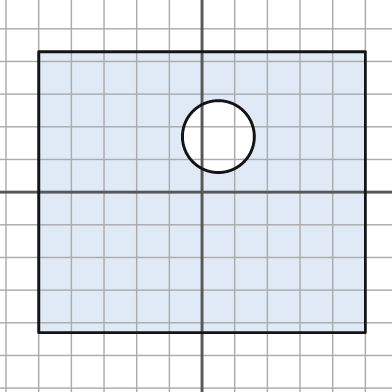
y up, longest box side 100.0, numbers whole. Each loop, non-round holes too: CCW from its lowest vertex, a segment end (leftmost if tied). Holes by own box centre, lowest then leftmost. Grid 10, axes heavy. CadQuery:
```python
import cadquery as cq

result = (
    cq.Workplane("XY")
    .moveTo(-50.0, -43.0)
    .lineTo(50.0, -43.0)
    .lineTo(50.0, 43.0)
    .lineTo(-50.0, 43.0)
    .close()
    .moveTo(5.0, 17.0)
    .circle(11.0)
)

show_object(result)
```